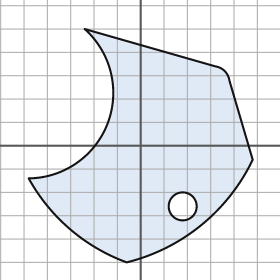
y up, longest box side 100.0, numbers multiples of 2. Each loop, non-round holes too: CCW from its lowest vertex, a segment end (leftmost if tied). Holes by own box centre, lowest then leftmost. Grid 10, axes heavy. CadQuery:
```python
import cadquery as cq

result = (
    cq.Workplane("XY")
    .moveTo(-6.0, -50.0)
    .threePointArc((26.0, -34.0), (48.0, -6.0))
    .lineTo(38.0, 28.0)
    .threePointArc((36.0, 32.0), (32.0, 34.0))
    .lineTo(-24.0, 50.0)
    .threePointArc((-14.0, 10.0), (-48.0, -14.0))
    .threePointArc((-30.0, -36.0), (-6.0, -50.0))
    .close()
    .moveTo(18.0, -26.0)
    .circle(6.0)
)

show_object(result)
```